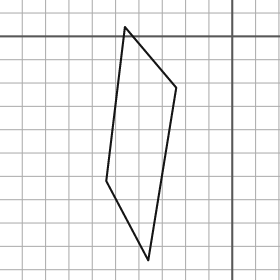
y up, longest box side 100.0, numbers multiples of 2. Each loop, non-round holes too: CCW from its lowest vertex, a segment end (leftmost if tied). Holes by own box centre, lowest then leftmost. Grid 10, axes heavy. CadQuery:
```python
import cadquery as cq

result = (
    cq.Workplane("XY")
    .moveTo(-36.0, -96.0)
    .lineTo(-24.0, -22.0)
    .lineTo(-46.0, 4.0)
    .lineTo(-54.0, -62.0)
    .close()
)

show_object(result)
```